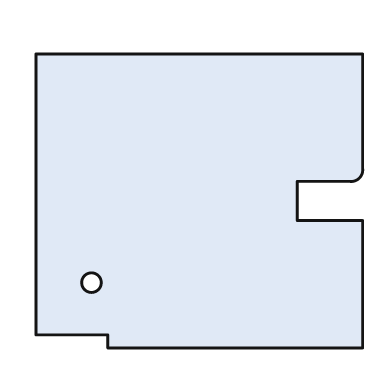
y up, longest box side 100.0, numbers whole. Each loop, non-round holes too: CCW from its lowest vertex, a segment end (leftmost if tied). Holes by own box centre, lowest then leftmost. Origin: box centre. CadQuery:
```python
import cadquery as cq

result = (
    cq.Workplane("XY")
    .moveTo(-28.0, -45.0)
    .lineTo(50.0, -45.0)
    .lineTo(50.0, -6.0)
    .lineTo(30.0, -6.0)
    .lineTo(30.0, 6.0)
    .lineTo(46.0, 6.0)
    .threePointArc((49.0, 7.0), (50.0, 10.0))
    .lineTo(50.0, 45.0)
    .lineTo(-50.0, 45.0)
    .lineTo(-50.0, -41.0)
    .lineTo(-28.0, -41.0)
    .close()
    .moveTo(-33.0, -25.0)
    .circle(3.0)
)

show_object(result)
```